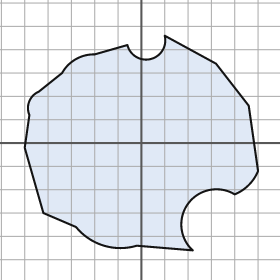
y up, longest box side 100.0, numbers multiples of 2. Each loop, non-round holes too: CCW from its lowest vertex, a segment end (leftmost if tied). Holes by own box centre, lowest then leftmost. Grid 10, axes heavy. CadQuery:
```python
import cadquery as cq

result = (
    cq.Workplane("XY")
    .moveTo(22.0, -46.0)
    .threePointArc((20.0, -26.0), (40.0, -22.0))
    .threePointArc((46.0, -18.0), (50.0, -12.0))
    .lineTo(46.0, 16.0)
    .lineTo(32.0, 34.0)
    .lineTo(10.0, 46.0)
    .threePointArc((4.0, 36.0), (-6.0, 42.0))
    .lineTo(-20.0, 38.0)
    .threePointArc((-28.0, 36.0), (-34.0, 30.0))
    .lineTo(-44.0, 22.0)
    .threePointArc((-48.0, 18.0), (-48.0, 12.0))
    .lineTo(-50.0, -2.0)
    .lineTo(-42.0, -30.0)
    .lineTo(-28.0, -36.0)
    .threePointArc((-16.0, -44.0), (-2.0, -44.0))
    .close()
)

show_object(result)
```